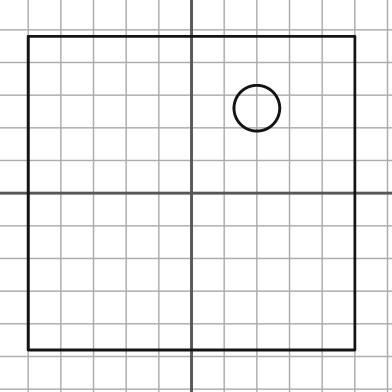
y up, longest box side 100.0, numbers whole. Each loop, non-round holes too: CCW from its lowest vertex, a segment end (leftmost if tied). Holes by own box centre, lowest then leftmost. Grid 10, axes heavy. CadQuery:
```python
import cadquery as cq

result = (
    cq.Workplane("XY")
    .moveTo(-50.0, -48.0)
    .lineTo(50.0, -48.0)
    .lineTo(50.0, 48.0)
    .lineTo(-50.0, 48.0)
    .close()
    .moveTo(20.0, 26.0)
    .circle(7.0)
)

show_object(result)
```